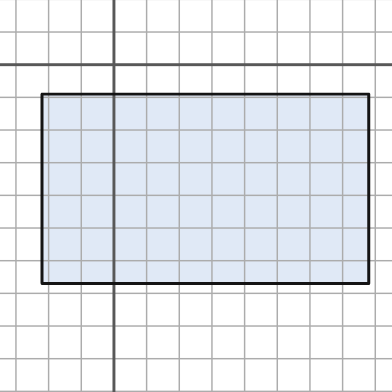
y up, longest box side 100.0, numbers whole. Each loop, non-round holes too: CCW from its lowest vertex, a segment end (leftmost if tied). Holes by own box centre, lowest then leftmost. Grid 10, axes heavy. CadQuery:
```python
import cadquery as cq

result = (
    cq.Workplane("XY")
    .moveTo(-22.0, -67.0)
    .lineTo(78.0, -67.0)
    .lineTo(78.0, -9.0)
    .lineTo(-22.0, -9.0)
    .close()
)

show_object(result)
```